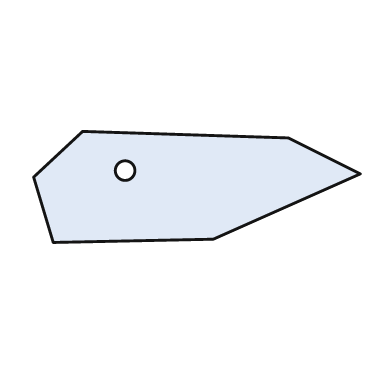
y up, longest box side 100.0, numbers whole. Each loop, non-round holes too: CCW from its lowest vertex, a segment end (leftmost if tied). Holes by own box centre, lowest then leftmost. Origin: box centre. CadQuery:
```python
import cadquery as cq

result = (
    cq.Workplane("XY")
    .moveTo(-44.0, -17.0)
    .lineTo(5.0, -16.0)
    .lineTo(50.0, 4.0)
    .lineTo(28.0, 15.0)
    .lineTo(-35.0, 17.0)
    .lineTo(-50.0, 3.0)
    .close()
    .moveTo(-22.0, 5.0)
    .circle(3.0)
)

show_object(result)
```